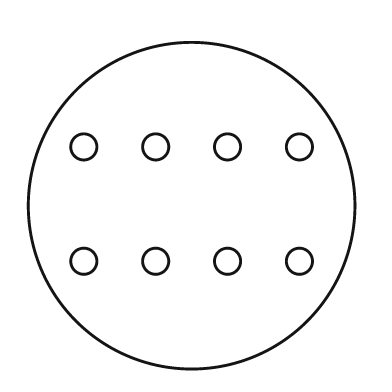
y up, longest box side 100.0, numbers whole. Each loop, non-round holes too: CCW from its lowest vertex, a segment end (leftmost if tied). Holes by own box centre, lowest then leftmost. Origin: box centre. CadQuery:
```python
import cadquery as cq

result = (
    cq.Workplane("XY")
    .moveTo(0.0, 0.0)
    .circle(50.0)
    .moveTo(-33.0, -17.0)
    .circle(4.0)
    .moveTo(-11.0, -17.0)
    .circle(4.0)
    .moveTo(11.0, -17.0)
    .circle(4.0)
    .moveTo(33.0, -17.0)
    .circle(4.0)
    .moveTo(-33.0, 18.0)
    .circle(4.0)
    .moveTo(-11.0, 18.0)
    .circle(4.0)
    .moveTo(11.0, 18.0)
    .circle(4.0)
    .moveTo(33.0, 18.0)
    .circle(4.0)
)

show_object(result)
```